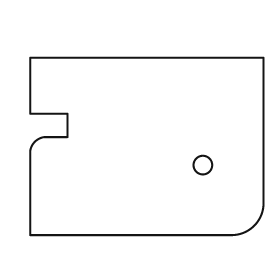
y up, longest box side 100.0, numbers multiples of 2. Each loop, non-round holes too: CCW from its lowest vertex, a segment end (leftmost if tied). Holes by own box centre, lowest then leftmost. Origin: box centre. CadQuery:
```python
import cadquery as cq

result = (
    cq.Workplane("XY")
    .moveTo(-50.0, -38.0)
    .lineTo(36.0, -38.0)
    .threePointArc((46.0, -34.0), (50.0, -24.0))
    .lineTo(50.0, 38.0)
    .lineTo(-50.0, 38.0)
    .lineTo(-50.0, 14.0)
    .lineTo(-34.0, 14.0)
    .lineTo(-34.0, 4.0)
    .lineTo(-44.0, 4.0)
    .threePointArc((-48.0, 2.0), (-50.0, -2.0))
    .close()
    .moveTo(24.0, -8.0)
    .circle(4.0)
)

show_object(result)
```